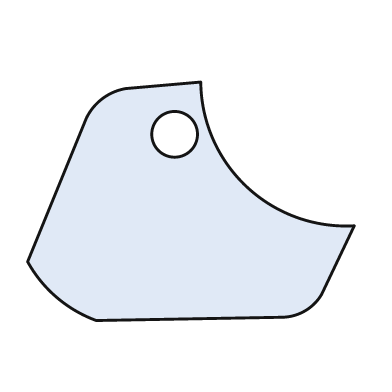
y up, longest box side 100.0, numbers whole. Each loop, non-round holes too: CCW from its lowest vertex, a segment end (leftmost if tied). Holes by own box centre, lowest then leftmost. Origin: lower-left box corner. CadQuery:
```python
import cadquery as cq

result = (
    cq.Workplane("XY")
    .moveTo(21.0, 0.0)
    .lineTo(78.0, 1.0)
    .threePointArc((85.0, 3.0), (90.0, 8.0))
    .lineTo(100.0, 29.0)
    .threePointArc((67.0, 41.0), (53.0, 73.0))
    .lineTo(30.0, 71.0)
    .threePointArc((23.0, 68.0), (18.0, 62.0))
    .lineTo(0.0, 18.0)
    .threePointArc((9.0, 7.0), (21.0, 0.0))
    .close()
    .moveTo(45.0, 57.0)
    .circle(7.0)
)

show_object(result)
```